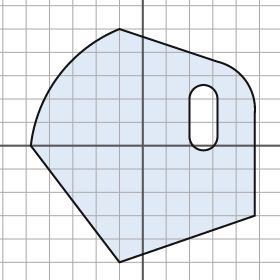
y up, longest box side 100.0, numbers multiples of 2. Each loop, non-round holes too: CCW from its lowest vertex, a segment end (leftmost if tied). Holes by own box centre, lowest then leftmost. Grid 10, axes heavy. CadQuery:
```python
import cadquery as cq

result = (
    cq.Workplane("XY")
    .moveTo(-10.0, -50.0)
    .lineTo(48.0, -30.0)
    .lineTo(48.0, 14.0)
    .threePointArc((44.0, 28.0), (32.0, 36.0))
    .lineTo(-10.0, 50.0)
    .threePointArc((-36.0, 30.0), (-48.0, 0.0))
    .close()
    .moveTo(20.0, 4.0)
    .threePointArc((26.0, -2.0), (32.0, 4.0))
    .lineTo(32.0, 20.0)
    .threePointArc((26.0, 26.0), (20.0, 20.0))
    .close()
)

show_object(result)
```